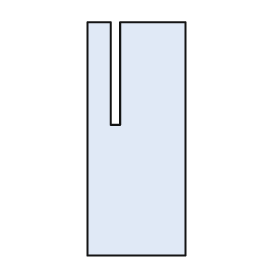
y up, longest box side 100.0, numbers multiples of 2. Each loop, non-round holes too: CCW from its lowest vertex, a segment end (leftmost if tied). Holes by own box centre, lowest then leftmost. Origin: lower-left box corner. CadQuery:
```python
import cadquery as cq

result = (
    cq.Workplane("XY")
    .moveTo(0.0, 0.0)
    .lineTo(42.0, 0.0)
    .lineTo(42.0, 100.0)
    .lineTo(14.0, 100.0)
    .lineTo(14.0, 56.0)
    .lineTo(10.0, 56.0)
    .lineTo(10.0, 100.0)
    .lineTo(0.0, 100.0)
    .close()
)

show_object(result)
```